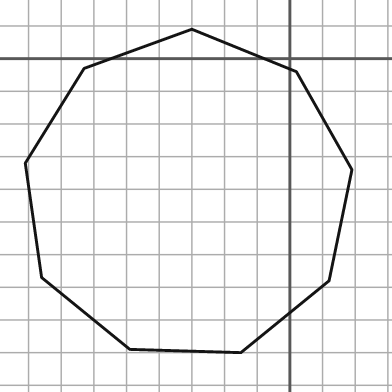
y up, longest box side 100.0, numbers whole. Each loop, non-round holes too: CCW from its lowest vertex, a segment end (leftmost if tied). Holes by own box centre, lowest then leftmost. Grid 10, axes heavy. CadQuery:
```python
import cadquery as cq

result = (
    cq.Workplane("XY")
    .moveTo(-15.0, -90.0)
    .lineTo(12.0, -68.0)
    .lineTo(19.0, -34.0)
    .lineTo(2.0, -4.0)
    .lineTo(-30.0, 9.0)
    .lineTo(-63.0, -3.0)
    .lineTo(-81.0, -32.0)
    .lineTo(-76.0, -67.0)
    .lineTo(-49.0, -89.0)
    .close()
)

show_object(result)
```